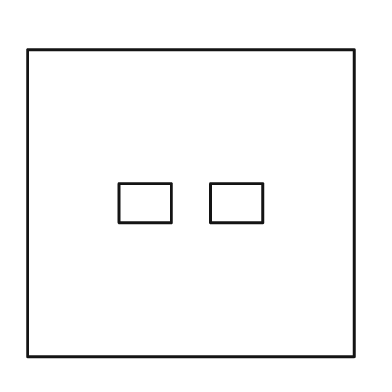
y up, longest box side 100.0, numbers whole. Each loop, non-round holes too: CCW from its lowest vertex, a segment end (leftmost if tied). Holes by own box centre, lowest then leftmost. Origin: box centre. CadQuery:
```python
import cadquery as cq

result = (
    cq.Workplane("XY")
    .moveTo(-50.0, -47.0)
    .lineTo(50.0, -47.0)
    .lineTo(50.0, 47.0)
    .lineTo(-50.0, 47.0)
    .close()
    .moveTo(-22.0, -6.0)
    .lineTo(-6.0, -6.0)
    .lineTo(-6.0, 6.0)
    .lineTo(-22.0, 6.0)
    .close()
    .moveTo(6.0, -6.0)
    .lineTo(22.0, -6.0)
    .lineTo(22.0, 6.0)
    .lineTo(6.0, 6.0)
    .close()
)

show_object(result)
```